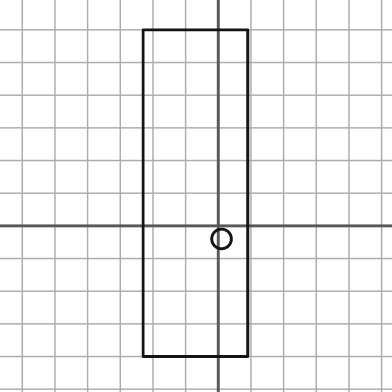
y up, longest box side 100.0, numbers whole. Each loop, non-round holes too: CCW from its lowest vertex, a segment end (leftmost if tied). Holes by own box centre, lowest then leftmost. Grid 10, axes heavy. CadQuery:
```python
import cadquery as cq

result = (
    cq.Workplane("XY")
    .moveTo(-23.0, -40.0)
    .lineTo(9.0, -40.0)
    .lineTo(9.0, 60.0)
    .lineTo(-23.0, 60.0)
    .close()
    .moveTo(1.0, -4.0)
    .circle(3.0)
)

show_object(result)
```